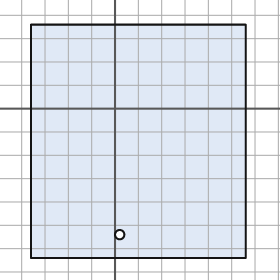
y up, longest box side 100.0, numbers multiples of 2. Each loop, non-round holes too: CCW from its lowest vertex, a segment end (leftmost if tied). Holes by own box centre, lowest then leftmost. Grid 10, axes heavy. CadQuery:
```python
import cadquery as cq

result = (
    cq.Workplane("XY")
    .moveTo(-36.0, -64.0)
    .lineTo(56.0, -64.0)
    .lineTo(56.0, 36.0)
    .lineTo(-36.0, 36.0)
    .close()
    .moveTo(2.0, -54.0)
    .circle(2.0)
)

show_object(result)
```